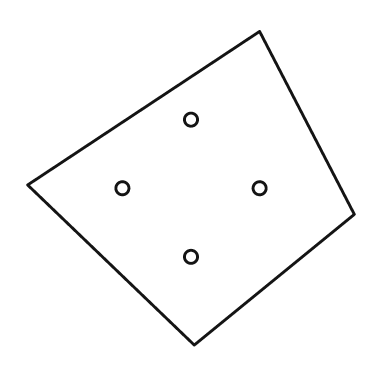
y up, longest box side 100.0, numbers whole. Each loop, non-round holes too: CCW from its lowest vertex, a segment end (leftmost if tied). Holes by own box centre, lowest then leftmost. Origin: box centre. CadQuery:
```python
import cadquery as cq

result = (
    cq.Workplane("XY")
    .moveTo(1.0, -48.0)
    .lineTo(50.0, -8.0)
    .lineTo(21.0, 48.0)
    .lineTo(-50.0, 1.0)
    .close()
    .moveTo(0.0, -21.0)
    .circle(2.0)
    .moveTo(-21.0, 0.0)
    .circle(2.0)
    .moveTo(21.0, 0.0)
    .circle(2.0)
    .moveTo(0.0, 21.0)
    .circle(2.0)
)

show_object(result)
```